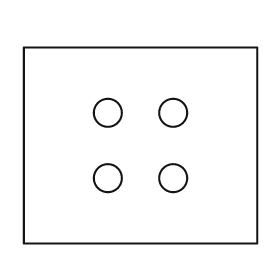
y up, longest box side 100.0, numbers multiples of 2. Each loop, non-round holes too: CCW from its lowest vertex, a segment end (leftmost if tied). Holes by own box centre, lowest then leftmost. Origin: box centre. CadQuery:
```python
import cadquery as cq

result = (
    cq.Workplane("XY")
    .moveTo(-50.0, -42.0)
    .lineTo(50.0, -42.0)
    .lineTo(50.0, 42.0)
    .lineTo(-50.0, 42.0)
    .close()
    .moveTo(-14.0, -14.0)
    .circle(6.0)
    .moveTo(14.0, -14.0)
    .circle(6.0)
    .moveTo(-14.0, 14.0)
    .circle(6.0)
    .moveTo(14.0, 14.0)
    .circle(6.0)
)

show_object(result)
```